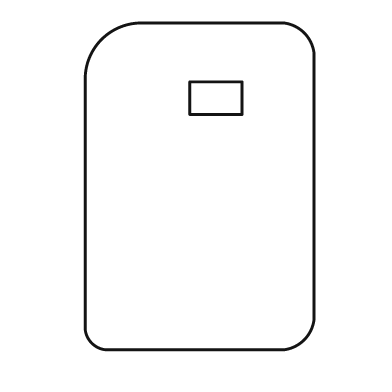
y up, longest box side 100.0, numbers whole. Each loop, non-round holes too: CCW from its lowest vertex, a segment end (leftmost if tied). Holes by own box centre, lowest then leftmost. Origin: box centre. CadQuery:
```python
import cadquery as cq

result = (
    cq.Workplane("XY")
    .moveTo(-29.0, -50.0)
    .lineTo(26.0, -50.0)
    .threePointArc((32.0, -47.0), (35.0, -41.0))
    .lineTo(35.0, 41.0)
    .threePointArc((32.0, 47.0), (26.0, 50.0))
    .lineTo(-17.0, 50.0)
    .threePointArc((-30.0, 45.0), (-35.0, 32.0))
    .lineTo(-35.0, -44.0)
    .threePointArc((-33.0, -48.0), (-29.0, -50.0))
    .close()
    .moveTo(-3.0, 22.0)
    .lineTo(13.0, 22.0)
    .lineTo(13.0, 32.0)
    .lineTo(-3.0, 32.0)
    .close()
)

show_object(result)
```